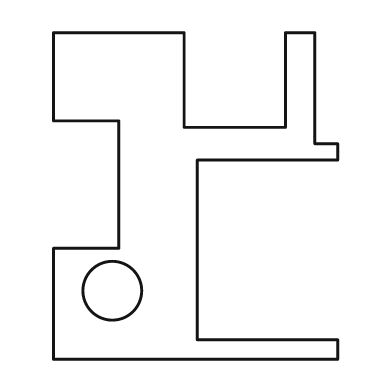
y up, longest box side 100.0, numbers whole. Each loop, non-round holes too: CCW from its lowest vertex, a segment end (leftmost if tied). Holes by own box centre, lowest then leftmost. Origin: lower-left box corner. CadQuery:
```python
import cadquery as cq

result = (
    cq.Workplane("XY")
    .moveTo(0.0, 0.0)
    .lineTo(87.0, 0.0)
    .lineTo(87.0, 6.0)
    .lineTo(44.0, 6.0)
    .lineTo(44.0, 61.0)
    .lineTo(87.0, 61.0)
    .lineTo(87.0, 66.0)
    .lineTo(80.0, 66.0)
    .lineTo(80.0, 100.0)
    .lineTo(71.0, 100.0)
    .lineTo(71.0, 71.0)
    .lineTo(40.0, 71.0)
    .lineTo(40.0, 100.0)
    .lineTo(0.0, 100.0)
    .lineTo(0.0, 73.0)
    .lineTo(20.0, 73.0)
    .lineTo(20.0, 34.0)
    .lineTo(0.0, 34.0)
    .close()
    .moveTo(18.0, 21.0)
    .circle(9.0)
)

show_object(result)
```